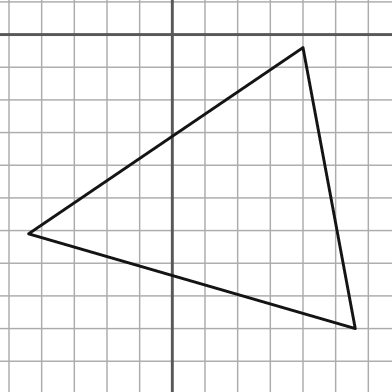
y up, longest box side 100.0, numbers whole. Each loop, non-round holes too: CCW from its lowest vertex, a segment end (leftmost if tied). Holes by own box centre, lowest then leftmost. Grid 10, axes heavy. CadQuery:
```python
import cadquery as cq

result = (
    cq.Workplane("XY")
    .moveTo(56.0, -90.0)
    .lineTo(40.0, -4.0)
    .lineTo(-44.0, -61.0)
    .close()
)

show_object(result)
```